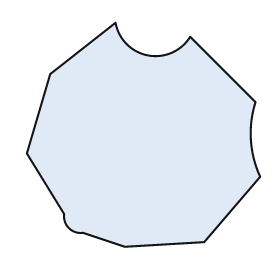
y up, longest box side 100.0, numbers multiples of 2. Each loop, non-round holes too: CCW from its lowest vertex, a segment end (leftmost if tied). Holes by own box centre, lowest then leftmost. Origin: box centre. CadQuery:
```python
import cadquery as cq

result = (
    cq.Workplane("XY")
    .moveTo(-8.0, -48.0)
    .lineTo(26.0, -46.0)
    .lineTo(50.0, -18.0)
    .threePointArc((46.0, -2.0), (48.0, 14.0))
    .lineTo(20.0, 42.0)
    .threePointArc((2.0, 34.0), (-12.0, 48.0))
    .lineTo(-40.0, 26.0)
    .lineTo(-50.0, -8.0)
    .lineTo(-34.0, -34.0)
    .threePointArc((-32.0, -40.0), (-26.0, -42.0))
    .close()
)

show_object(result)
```